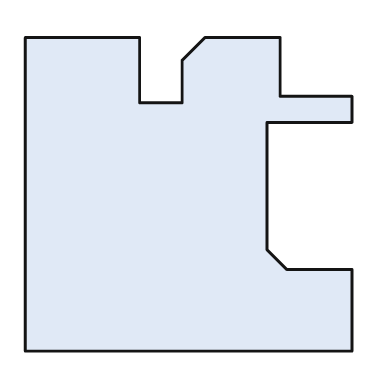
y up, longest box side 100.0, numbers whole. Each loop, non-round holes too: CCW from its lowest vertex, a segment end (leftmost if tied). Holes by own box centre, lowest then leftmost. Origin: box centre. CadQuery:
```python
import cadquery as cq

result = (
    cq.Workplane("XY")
    .moveTo(-50.0, -48.0)
    .lineTo(50.0, -48.0)
    .lineTo(50.0, -23.0)
    .lineTo(30.0, -23.0)
    .lineTo(24.0, -17.0)
    .lineTo(24.0, 22.0)
    .lineTo(50.0, 22.0)
    .lineTo(50.0, 30.0)
    .lineTo(28.0, 30.0)
    .lineTo(28.0, 48.0)
    .lineTo(5.0, 48.0)
    .lineTo(-2.0, 41.0)
    .lineTo(-2.0, 28.0)
    .lineTo(-15.0, 28.0)
    .lineTo(-15.0, 48.0)
    .lineTo(-50.0, 48.0)
    .close()
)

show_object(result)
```